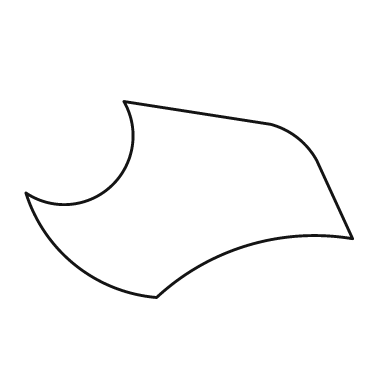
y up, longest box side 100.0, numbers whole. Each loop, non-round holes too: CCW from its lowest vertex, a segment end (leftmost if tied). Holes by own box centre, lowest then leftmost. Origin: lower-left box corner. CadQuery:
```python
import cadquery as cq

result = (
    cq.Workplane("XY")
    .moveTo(40.0, 0.0)
    .threePointArc((68.0, 16.0), (100.0, 18.0))
    .lineTo(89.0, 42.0)
    .threePointArc((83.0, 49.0), (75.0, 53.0))
    .lineTo(30.0, 60.0)
    .threePointArc((26.0, 34.0), (0.0, 32.0))
    .threePointArc((15.0, 10.0), (40.0, 0.0))
    .close()
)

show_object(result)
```